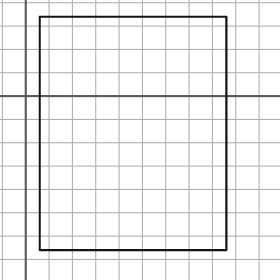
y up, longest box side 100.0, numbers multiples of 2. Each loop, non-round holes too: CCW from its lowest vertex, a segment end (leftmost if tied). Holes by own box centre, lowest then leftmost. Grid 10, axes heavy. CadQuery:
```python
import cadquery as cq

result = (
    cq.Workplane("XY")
    .moveTo(6.0, -66.0)
    .lineTo(86.0, -66.0)
    .lineTo(86.0, 34.0)
    .lineTo(6.0, 34.0)
    .close()
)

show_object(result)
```